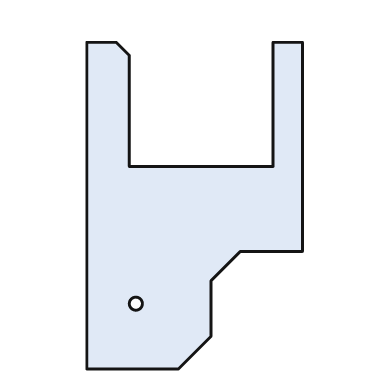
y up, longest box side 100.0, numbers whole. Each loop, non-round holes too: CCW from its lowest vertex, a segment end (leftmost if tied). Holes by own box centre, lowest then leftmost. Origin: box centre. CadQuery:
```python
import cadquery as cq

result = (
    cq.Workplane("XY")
    .moveTo(-33.0, -50.0)
    .lineTo(-5.0, -50.0)
    .lineTo(5.0, -40.0)
    .lineTo(5.0, -23.0)
    .lineTo(14.0, -14.0)
    .lineTo(33.0, -14.0)
    .lineTo(33.0, 50.0)
    .lineTo(24.0, 50.0)
    .lineTo(24.0, 12.0)
    .lineTo(-20.0, 12.0)
    .lineTo(-20.0, 46.0)
    .lineTo(-24.0, 50.0)
    .lineTo(-33.0, 50.0)
    .close()
    .moveTo(-18.0, -30.0)
    .circle(2.0)
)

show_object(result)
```